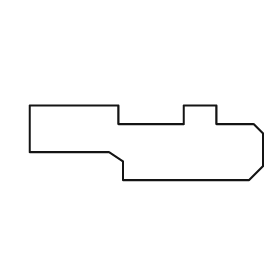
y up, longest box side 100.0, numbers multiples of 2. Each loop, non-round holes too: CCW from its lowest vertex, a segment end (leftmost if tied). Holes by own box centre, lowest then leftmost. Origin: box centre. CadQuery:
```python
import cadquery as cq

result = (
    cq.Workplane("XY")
    .moveTo(-10.0, -16.0)
    .lineTo(44.0, -16.0)
    .lineTo(50.0, -10.0)
    .lineTo(50.0, 4.0)
    .lineTo(46.0, 8.0)
    .lineTo(30.0, 8.0)
    .lineTo(30.0, 16.0)
    .lineTo(16.0, 16.0)
    .lineTo(16.0, 8.0)
    .lineTo(-12.0, 8.0)
    .lineTo(-12.0, 16.0)
    .lineTo(-50.0, 16.0)
    .lineTo(-50.0, -4.0)
    .lineTo(-16.0, -4.0)
    .lineTo(-10.0, -8.0)
    .close()
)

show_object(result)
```